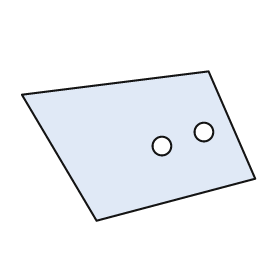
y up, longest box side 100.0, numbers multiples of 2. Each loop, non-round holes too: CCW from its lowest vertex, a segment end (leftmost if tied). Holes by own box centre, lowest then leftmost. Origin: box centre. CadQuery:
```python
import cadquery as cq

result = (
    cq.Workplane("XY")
    .moveTo(-18.0, -32.0)
    .lineTo(50.0, -14.0)
    .lineTo(30.0, 32.0)
    .lineTo(-50.0, 22.0)
    .close()
    .moveTo(10.0, 0.0)
    .circle(4.0)
    .moveTo(28.0, 6.0)
    .circle(4.0)
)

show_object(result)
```